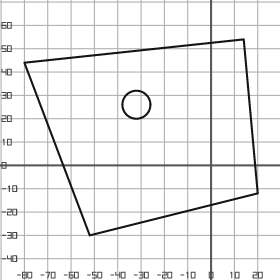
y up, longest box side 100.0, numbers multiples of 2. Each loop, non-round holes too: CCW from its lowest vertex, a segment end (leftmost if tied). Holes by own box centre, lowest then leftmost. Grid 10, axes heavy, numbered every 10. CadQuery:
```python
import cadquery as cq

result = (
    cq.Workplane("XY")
    .moveTo(-52.0, -30.0)
    .lineTo(20.0, -12.0)
    .lineTo(14.0, 54.0)
    .lineTo(-80.0, 44.0)
    .close()
    .moveTo(-32.0, 26.0)
    .circle(6.0)
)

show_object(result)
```